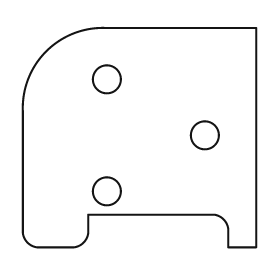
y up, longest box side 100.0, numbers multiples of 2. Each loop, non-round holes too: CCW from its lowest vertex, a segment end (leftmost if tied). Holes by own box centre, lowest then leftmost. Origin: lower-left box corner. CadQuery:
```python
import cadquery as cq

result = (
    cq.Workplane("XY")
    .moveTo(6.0, 0.0)
    .lineTo(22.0, 0.0)
    .threePointArc((26.0, 2.0), (28.0, 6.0))
    .lineTo(28.0, 14.0)
    .lineTo(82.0, 14.0)
    .threePointArc((86.0, 12.0), (88.0, 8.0))
    .lineTo(88.0, 0.0)
    .lineTo(100.0, 0.0)
    .lineTo(100.0, 94.0)
    .lineTo(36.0, 94.0)
    .threePointArc((10.0, 84.0), (0.0, 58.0))
    .lineTo(0.0, 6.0)
    .threePointArc((2.0, 2.0), (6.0, 0.0))
    .close()
    .moveTo(36.0, 24.0)
    .circle(6.0)
    .moveTo(78.0, 48.0)
    .circle(6.0)
    .moveTo(36.0, 72.0)
    .circle(6.0)
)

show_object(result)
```